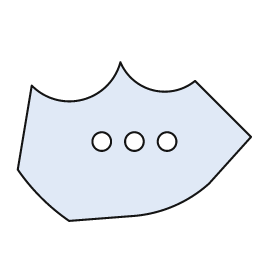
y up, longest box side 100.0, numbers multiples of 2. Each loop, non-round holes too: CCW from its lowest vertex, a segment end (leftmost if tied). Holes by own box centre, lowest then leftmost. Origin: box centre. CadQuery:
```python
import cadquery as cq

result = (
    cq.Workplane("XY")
    .moveTo(-28.0, -34.0)
    .lineTo(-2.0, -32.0)
    .threePointArc((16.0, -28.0), (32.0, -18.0))
    .lineTo(50.0, 2.0)
    .lineTo(26.0, 26.0)
    .threePointArc((8.0, 22.0), (-6.0, 34.0))
    .threePointArc((-22.0, 18.0), (-44.0, 24.0))
    .lineTo(-50.0, -12.0)
    .threePointArc((-40.0, -24.0), (-28.0, -34.0))
    .close()
    .moveTo(-14.0, 0.0)
    .circle(4.0)
    .moveTo(0.0, 0.0)
    .circle(4.0)
    .moveTo(14.0, 0.0)
    .circle(4.0)
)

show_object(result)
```